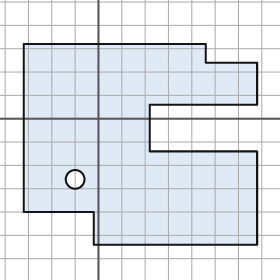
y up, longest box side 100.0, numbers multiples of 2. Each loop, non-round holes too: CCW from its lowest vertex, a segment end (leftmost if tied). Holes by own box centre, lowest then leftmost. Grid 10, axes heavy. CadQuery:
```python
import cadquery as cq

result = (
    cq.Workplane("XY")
    .moveTo(-2.0, -54.0)
    .lineTo(68.0, -54.0)
    .lineTo(68.0, -14.0)
    .lineTo(22.0, -14.0)
    .lineTo(22.0, 6.0)
    .lineTo(68.0, 6.0)
    .lineTo(68.0, 24.0)
    .lineTo(46.0, 24.0)
    .lineTo(46.0, 32.0)
    .lineTo(-32.0, 32.0)
    .lineTo(-32.0, -40.0)
    .lineTo(-2.0, -40.0)
    .close()
    .moveTo(-10.0, -26.0)
    .circle(4.0)
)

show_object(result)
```